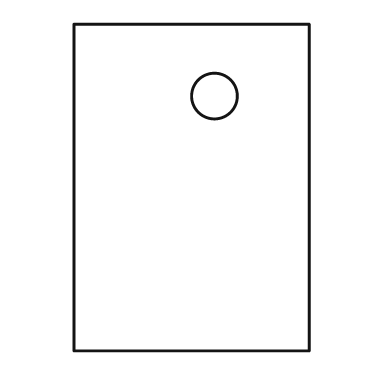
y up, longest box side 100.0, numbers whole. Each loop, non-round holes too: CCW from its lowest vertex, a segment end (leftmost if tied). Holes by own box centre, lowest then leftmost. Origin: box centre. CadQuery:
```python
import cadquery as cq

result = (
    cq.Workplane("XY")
    .moveTo(-36.0, -50.0)
    .lineTo(36.0, -50.0)
    .lineTo(36.0, 50.0)
    .lineTo(-36.0, 50.0)
    .close()
    .moveTo(7.0, 28.0)
    .circle(7.0)
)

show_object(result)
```